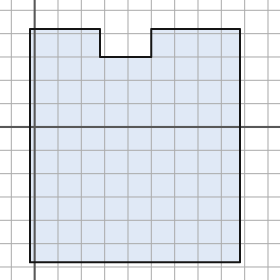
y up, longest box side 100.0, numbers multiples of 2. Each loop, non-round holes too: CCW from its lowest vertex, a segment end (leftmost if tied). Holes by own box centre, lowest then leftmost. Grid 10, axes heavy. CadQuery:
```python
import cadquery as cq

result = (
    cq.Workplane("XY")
    .moveTo(-2.0, -58.0)
    .lineTo(88.0, -58.0)
    .lineTo(88.0, 42.0)
    .lineTo(50.0, 42.0)
    .lineTo(50.0, 30.0)
    .lineTo(28.0, 30.0)
    .lineTo(28.0, 42.0)
    .lineTo(-2.0, 42.0)
    .close()
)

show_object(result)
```